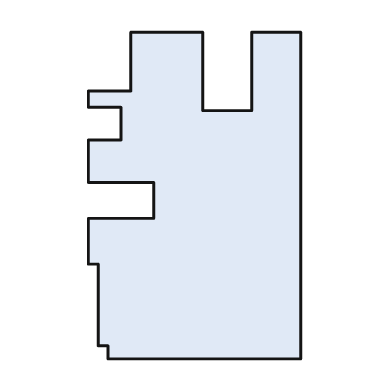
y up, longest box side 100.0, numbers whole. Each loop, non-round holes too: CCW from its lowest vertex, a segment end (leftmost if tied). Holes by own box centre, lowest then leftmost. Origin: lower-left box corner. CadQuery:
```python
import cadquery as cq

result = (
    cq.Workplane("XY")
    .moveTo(6.0, 0.0)
    .lineTo(65.0, 0.0)
    .lineTo(65.0, 100.0)
    .lineTo(50.0, 100.0)
    .lineTo(50.0, 76.0)
    .lineTo(35.0, 76.0)
    .lineTo(35.0, 100.0)
    .lineTo(13.0, 100.0)
    .lineTo(13.0, 82.0)
    .lineTo(0.0, 82.0)
    .lineTo(0.0, 77.0)
    .lineTo(10.0, 77.0)
    .lineTo(10.0, 67.0)
    .lineTo(0.0, 67.0)
    .lineTo(0.0, 54.0)
    .lineTo(20.0, 54.0)
    .lineTo(20.0, 43.0)
    .lineTo(0.0, 43.0)
    .lineTo(0.0, 29.0)
    .lineTo(3.0, 29.0)
    .lineTo(3.0, 4.0)
    .lineTo(6.0, 4.0)
    .close()
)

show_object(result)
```